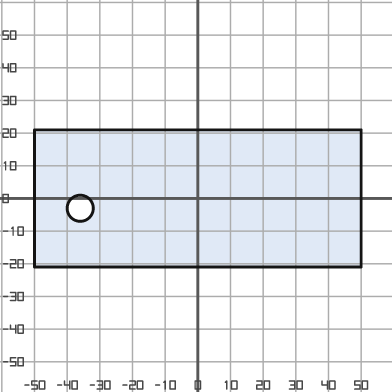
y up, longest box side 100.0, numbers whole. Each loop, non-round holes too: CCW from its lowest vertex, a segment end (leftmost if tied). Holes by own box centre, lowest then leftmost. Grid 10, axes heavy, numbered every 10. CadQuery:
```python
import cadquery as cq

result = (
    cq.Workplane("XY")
    .moveTo(-50.0, -21.0)
    .lineTo(50.0, -21.0)
    .lineTo(50.0, 21.0)
    .lineTo(-50.0, 21.0)
    .close()
    .moveTo(-36.0, -3.0)
    .circle(4.0)
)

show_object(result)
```